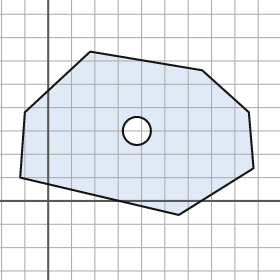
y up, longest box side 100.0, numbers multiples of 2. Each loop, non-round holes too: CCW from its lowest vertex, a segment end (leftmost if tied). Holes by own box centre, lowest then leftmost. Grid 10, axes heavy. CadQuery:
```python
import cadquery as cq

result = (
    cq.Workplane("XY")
    .moveTo(56.0, -6.0)
    .lineTo(88.0, 14.0)
    .lineTo(86.0, 38.0)
    .lineTo(66.0, 56.0)
    .lineTo(18.0, 64.0)
    .lineTo(-10.0, 38.0)
    .lineTo(-12.0, 10.0)
    .close()
    .moveTo(38.0, 30.0)
    .circle(6.0)
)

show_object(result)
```